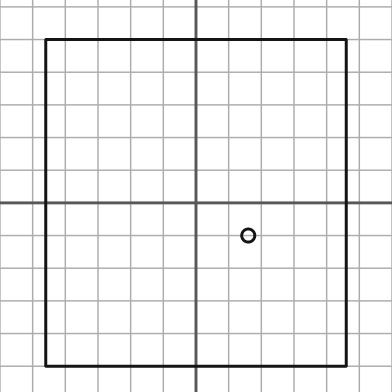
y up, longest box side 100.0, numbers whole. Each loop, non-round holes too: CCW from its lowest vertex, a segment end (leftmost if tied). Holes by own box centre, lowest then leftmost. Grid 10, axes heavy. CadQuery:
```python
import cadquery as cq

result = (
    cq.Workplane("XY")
    .moveTo(-46.0, -50.0)
    .lineTo(46.0, -50.0)
    .lineTo(46.0, 50.0)
    .lineTo(-46.0, 50.0)
    .close()
    .moveTo(16.0, -10.0)
    .circle(2.0)
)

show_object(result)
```